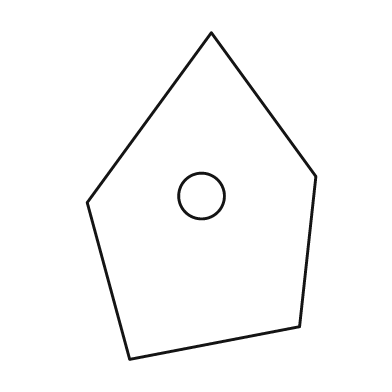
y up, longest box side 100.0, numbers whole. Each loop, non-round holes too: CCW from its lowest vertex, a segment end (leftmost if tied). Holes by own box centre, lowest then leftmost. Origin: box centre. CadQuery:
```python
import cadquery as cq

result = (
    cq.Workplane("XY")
    .moveTo(-22.0, -50.0)
    .lineTo(30.0, -40.0)
    .lineTo(35.0, 6.0)
    .lineTo(3.0, 50.0)
    .lineTo(-35.0, -2.0)
    .close()
    .moveTo(0.0, 0.0)
    .circle(7.0)
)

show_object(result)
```